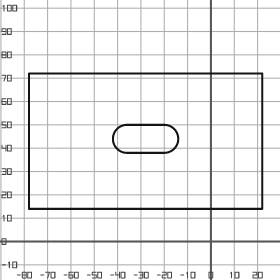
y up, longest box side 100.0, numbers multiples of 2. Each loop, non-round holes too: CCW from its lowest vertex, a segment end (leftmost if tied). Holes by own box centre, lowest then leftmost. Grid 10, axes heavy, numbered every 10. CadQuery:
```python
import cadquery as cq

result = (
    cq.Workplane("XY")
    .moveTo(-78.0, 14.0)
    .lineTo(22.0, 14.0)
    .lineTo(22.0, 72.0)
    .lineTo(-78.0, 72.0)
    .close()
    .moveTo(-36.0, 38.0)
    .lineTo(-20.0, 38.0)
    .threePointArc((-14.0, 44.0), (-20.0, 50.0))
    .lineTo(-36.0, 50.0)
    .threePointArc((-42.0, 44.0), (-36.0, 38.0))
    .close()
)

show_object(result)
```